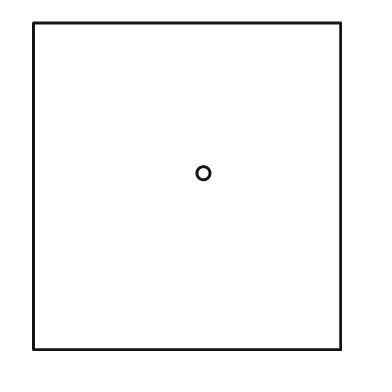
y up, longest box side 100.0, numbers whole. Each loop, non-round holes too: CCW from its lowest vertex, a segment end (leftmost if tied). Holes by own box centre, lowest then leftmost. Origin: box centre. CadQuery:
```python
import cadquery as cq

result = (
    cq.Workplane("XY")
    .moveTo(-47.0, -50.0)
    .lineTo(47.0, -50.0)
    .lineTo(47.0, 50.0)
    .lineTo(-47.0, 50.0)
    .close()
    .moveTo(5.0, 4.0)
    .circle(2.0)
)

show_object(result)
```